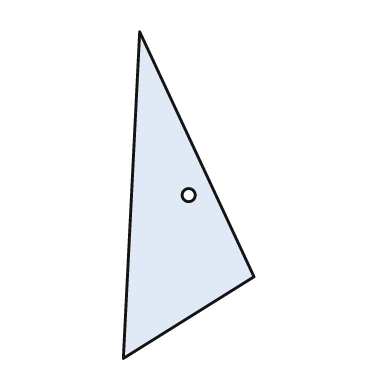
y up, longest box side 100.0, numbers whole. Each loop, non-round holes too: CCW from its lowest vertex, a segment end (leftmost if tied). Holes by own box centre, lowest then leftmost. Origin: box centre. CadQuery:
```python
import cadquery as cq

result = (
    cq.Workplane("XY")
    .moveTo(-20.0, -50.0)
    .lineTo(20.0, -25.0)
    .lineTo(-15.0, 50.0)
    .close()
    .moveTo(0.0, 0.0)
    .circle(2.0)
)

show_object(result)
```